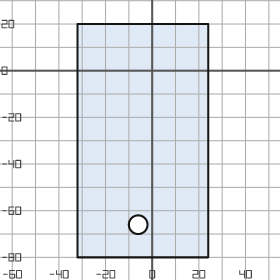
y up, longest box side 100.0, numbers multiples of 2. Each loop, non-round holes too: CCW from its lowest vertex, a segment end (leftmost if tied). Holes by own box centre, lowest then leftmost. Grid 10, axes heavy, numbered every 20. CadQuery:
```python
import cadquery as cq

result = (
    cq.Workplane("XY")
    .moveTo(-32.0, -80.0)
    .lineTo(24.0, -80.0)
    .lineTo(24.0, 20.0)
    .lineTo(-32.0, 20.0)
    .close()
    .moveTo(-6.0, -66.0)
    .circle(4.0)
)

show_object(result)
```